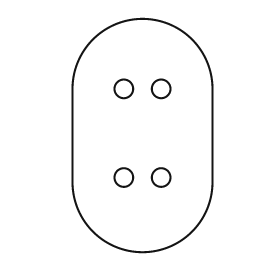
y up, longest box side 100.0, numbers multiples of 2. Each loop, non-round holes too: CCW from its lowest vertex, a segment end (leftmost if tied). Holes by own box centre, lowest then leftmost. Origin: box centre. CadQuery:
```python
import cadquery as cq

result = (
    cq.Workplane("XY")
    .moveTo(-30.0, -20.0)
    .threePointArc((0.0, -50.0), (30.0, -20.0))
    .lineTo(30.0, 20.0)
    .threePointArc((0.0, 50.0), (-30.0, 20.0))
    .close()
    .moveTo(-8.0, -18.0)
    .circle(4.0)
    .moveTo(8.0, -18.0)
    .circle(4.0)
    .moveTo(-8.0, 20.0)
    .circle(4.0)
    .moveTo(8.0, 20.0)
    .circle(4.0)
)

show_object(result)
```